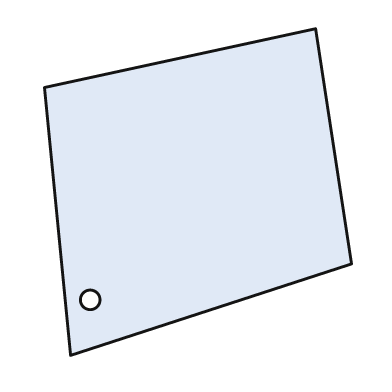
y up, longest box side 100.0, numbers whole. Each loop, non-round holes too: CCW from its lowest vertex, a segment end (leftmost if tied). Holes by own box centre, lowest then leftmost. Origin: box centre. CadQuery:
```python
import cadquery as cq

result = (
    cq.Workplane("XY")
    .moveTo(-39.0, -50.0)
    .lineTo(47.0, -22.0)
    .lineTo(36.0, 50.0)
    .lineTo(-47.0, 32.0)
    .close()
    .moveTo(-33.0, -33.0)
    .circle(3.0)
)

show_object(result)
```